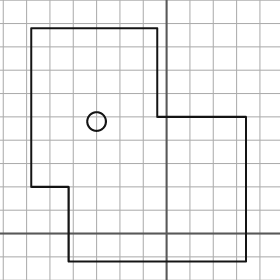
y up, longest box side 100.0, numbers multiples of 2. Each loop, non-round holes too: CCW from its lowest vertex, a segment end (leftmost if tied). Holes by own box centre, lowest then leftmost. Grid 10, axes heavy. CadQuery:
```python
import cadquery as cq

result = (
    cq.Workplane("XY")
    .moveTo(-42.0, -12.0)
    .lineTo(34.0, -12.0)
    .lineTo(34.0, 50.0)
    .lineTo(-4.0, 50.0)
    .lineTo(-4.0, 88.0)
    .lineTo(-58.0, 88.0)
    .lineTo(-58.0, 20.0)
    .lineTo(-42.0, 20.0)
    .close()
    .moveTo(-30.0, 48.0)
    .circle(4.0)
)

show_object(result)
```